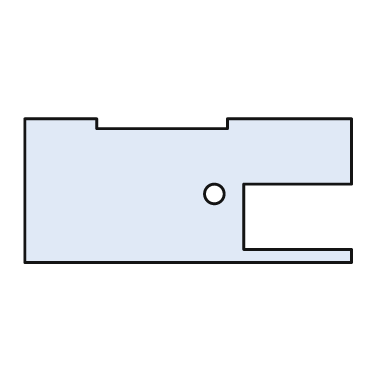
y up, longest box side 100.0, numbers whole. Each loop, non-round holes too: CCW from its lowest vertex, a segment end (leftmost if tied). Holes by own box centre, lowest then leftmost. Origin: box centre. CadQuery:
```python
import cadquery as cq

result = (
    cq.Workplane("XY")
    .moveTo(-50.0, -22.0)
    .lineTo(50.0, -22.0)
    .lineTo(50.0, -18.0)
    .lineTo(17.0, -18.0)
    .lineTo(17.0, 2.0)
    .lineTo(50.0, 2.0)
    .lineTo(50.0, 22.0)
    .lineTo(12.0, 22.0)
    .lineTo(12.0, 19.0)
    .lineTo(-28.0, 19.0)
    .lineTo(-28.0, 22.0)
    .lineTo(-50.0, 22.0)
    .close()
    .moveTo(8.0, -1.0)
    .circle(3.0)
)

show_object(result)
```